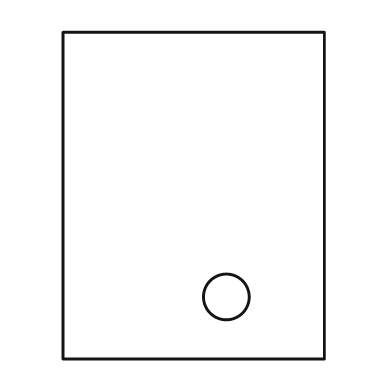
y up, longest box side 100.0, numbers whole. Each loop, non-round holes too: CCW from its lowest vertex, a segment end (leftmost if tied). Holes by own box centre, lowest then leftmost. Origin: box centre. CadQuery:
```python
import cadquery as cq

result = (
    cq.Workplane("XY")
    .moveTo(-40.0, -50.0)
    .lineTo(40.0, -50.0)
    .lineTo(40.0, 50.0)
    .lineTo(-40.0, 50.0)
    .close()
    .moveTo(10.0, -31.0)
    .circle(7.0)
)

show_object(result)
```